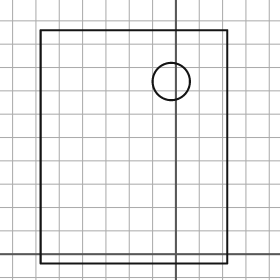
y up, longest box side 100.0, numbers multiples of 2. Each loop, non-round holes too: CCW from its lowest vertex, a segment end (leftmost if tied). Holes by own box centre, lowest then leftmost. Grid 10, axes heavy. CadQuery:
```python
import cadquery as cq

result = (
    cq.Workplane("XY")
    .moveTo(-58.0, -4.0)
    .lineTo(22.0, -4.0)
    .lineTo(22.0, 96.0)
    .lineTo(-58.0, 96.0)
    .close()
    .moveTo(-2.0, 74.0)
    .circle(8.0)
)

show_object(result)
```